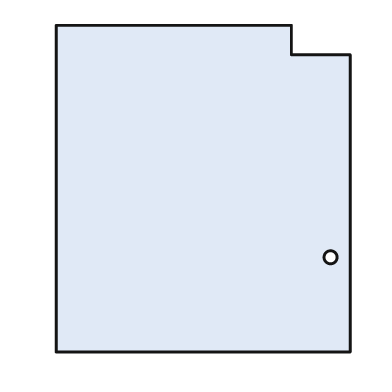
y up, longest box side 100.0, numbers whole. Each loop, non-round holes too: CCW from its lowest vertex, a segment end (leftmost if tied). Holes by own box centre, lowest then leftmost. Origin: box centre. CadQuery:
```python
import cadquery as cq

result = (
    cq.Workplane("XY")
    .moveTo(-45.0, -50.0)
    .lineTo(45.0, -50.0)
    .lineTo(45.0, 41.0)
    .lineTo(27.0, 41.0)
    .lineTo(27.0, 50.0)
    .lineTo(-45.0, 50.0)
    .close()
    .moveTo(39.0, -21.0)
    .circle(2.0)
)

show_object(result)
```